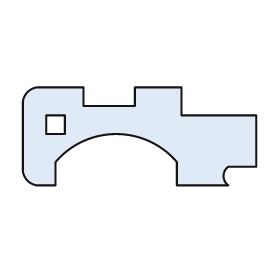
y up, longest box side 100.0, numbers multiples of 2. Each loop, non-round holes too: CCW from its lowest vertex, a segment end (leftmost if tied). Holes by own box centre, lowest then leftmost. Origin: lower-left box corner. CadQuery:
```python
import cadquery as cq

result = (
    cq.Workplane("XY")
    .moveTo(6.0, 0.0)
    .lineTo(14.0, 0.0)
    .lineTo(14.0, 10.0)
    .threePointArc((40.0, 22.0), (66.0, 10.0))
    .lineTo(66.0, 0.0)
    .lineTo(88.0, 0.0)
    .threePointArc((86.0, 4.0), (88.0, 8.0))
    .lineTo(100.0, 8.0)
    .lineTo(100.0, 30.0)
    .lineTo(68.0, 30.0)
    .lineTo(68.0, 42.0)
    .lineTo(48.0, 42.0)
    .lineTo(48.0, 34.0)
    .lineTo(26.0, 34.0)
    .lineTo(26.0, 42.0)
    .lineTo(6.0, 42.0)
    .threePointArc((2.0, 40.0), (0.0, 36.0))
    .lineTo(0.0, 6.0)
    .threePointArc((2.0, 2.0), (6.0, 0.0))
    .close()
    .moveTo(10.0, 22.0)
    .lineTo(18.0, 22.0)
    .lineTo(18.0, 30.0)
    .lineTo(10.0, 30.0)
    .close()
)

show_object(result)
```